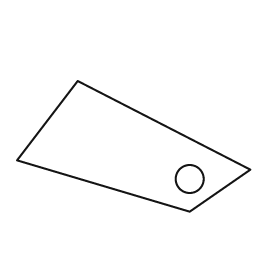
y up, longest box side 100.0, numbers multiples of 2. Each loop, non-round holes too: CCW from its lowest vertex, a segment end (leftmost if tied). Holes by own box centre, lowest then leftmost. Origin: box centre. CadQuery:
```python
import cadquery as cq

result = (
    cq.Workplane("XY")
    .moveTo(24.0, -28.0)
    .lineTo(50.0, -10.0)
    .lineTo(-24.0, 28.0)
    .lineTo(-50.0, -6.0)
    .close()
    .moveTo(24.0, -14.0)
    .circle(6.0)
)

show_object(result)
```